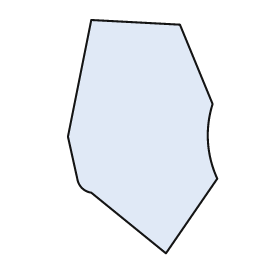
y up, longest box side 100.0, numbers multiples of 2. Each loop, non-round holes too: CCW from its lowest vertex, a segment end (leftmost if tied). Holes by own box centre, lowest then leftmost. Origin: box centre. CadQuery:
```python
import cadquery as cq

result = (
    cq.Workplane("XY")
    .moveTo(10.0, -50.0)
    .lineTo(32.0, -18.0)
    .threePointArc((28.0, -2.0), (30.0, 14.0))
    .lineTo(16.0, 48.0)
    .lineTo(-22.0, 50.0)
    .lineTo(-32.0, 0.0)
    .lineTo(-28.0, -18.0)
    .threePointArc((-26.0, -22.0), (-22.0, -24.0))
    .close()
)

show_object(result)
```